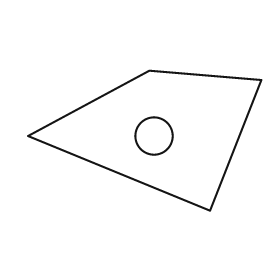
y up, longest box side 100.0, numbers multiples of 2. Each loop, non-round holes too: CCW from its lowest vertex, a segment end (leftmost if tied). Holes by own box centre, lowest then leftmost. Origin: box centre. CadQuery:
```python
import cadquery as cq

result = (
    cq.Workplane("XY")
    .moveTo(28.0, -30.0)
    .lineTo(50.0, 26.0)
    .lineTo(2.0, 30.0)
    .lineTo(-50.0, 2.0)
    .close()
    .moveTo(4.0, 2.0)
    .circle(8.0)
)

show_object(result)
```